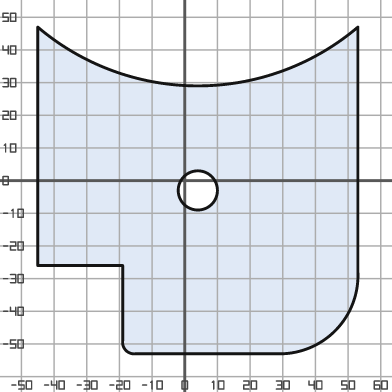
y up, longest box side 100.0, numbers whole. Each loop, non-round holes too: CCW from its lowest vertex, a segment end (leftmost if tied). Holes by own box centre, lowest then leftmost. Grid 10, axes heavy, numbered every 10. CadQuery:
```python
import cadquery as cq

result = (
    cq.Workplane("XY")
    .moveTo(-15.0, -53.0)
    .lineTo(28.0, -53.0)
    .threePointArc((46.0, -46.0), (53.0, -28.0))
    .lineTo(53.0, 47.0)
    .threePointArc((4.0, 29.0), (-45.0, 47.0))
    .lineTo(-45.0, -26.0)
    .lineTo(-19.0, -26.0)
    .lineTo(-19.0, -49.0)
    .threePointArc((-18.0, -52.0), (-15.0, -53.0))
    .close()
    .moveTo(4.0, -3.0)
    .circle(6.0)
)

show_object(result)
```